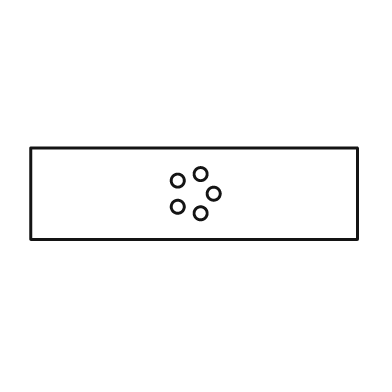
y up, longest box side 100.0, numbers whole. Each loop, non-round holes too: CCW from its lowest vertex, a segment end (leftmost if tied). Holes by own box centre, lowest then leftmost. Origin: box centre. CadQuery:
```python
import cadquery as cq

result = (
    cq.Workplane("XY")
    .moveTo(-50.0, -14.0)
    .lineTo(50.0, -14.0)
    .lineTo(50.0, 14.0)
    .lineTo(-50.0, 14.0)
    .close()
    .moveTo(2.0, -6.0)
    .circle(2.0)
    .moveTo(-5.0, -4.0)
    .circle(2.0)
    .moveTo(6.0, 0.0)
    .circle(2.0)
    .moveTo(-5.0, 4.0)
    .circle(2.0)
    .moveTo(2.0, 6.0)
    .circle(2.0)
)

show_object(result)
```